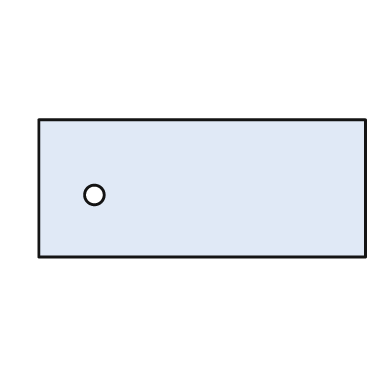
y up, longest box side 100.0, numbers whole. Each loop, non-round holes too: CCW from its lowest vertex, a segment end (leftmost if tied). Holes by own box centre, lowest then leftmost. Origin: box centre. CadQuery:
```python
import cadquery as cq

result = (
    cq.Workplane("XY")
    .moveTo(-50.0, -21.0)
    .lineTo(50.0, -21.0)
    .lineTo(50.0, 21.0)
    .lineTo(-50.0, 21.0)
    .close()
    .moveTo(-33.0, -2.0)
    .circle(3.0)
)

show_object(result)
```